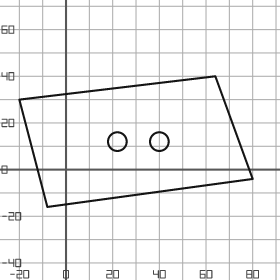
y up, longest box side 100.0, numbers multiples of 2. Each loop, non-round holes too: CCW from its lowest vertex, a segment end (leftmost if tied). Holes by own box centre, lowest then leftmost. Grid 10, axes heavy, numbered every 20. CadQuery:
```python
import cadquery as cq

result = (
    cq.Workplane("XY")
    .moveTo(-8.0, -16.0)
    .lineTo(80.0, -4.0)
    .lineTo(64.0, 40.0)
    .lineTo(-20.0, 30.0)
    .close()
    .moveTo(22.0, 12.0)
    .circle(4.0)
    .moveTo(40.0, 12.0)
    .circle(4.0)
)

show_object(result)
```